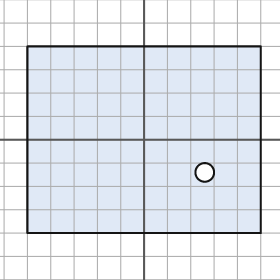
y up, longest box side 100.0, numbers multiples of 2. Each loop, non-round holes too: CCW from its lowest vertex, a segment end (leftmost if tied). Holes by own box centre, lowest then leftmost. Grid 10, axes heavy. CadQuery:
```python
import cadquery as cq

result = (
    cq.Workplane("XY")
    .moveTo(-50.0, -40.0)
    .lineTo(50.0, -40.0)
    .lineTo(50.0, 40.0)
    .lineTo(-50.0, 40.0)
    .close()
    .moveTo(26.0, -14.0)
    .circle(4.0)
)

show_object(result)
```